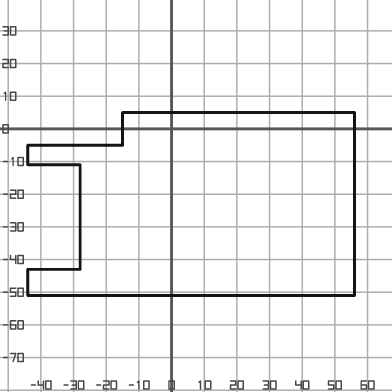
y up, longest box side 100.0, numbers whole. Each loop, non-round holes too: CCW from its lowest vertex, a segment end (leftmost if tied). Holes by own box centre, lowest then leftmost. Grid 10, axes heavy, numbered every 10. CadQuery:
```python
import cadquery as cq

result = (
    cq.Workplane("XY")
    .moveTo(-44.0, -51.0)
    .lineTo(56.0, -51.0)
    .lineTo(56.0, 5.0)
    .lineTo(-15.0, 5.0)
    .lineTo(-15.0, -5.0)
    .lineTo(-44.0, -5.0)
    .lineTo(-44.0, -11.0)
    .lineTo(-28.0, -11.0)
    .lineTo(-28.0, -43.0)
    .lineTo(-44.0, -43.0)
    .close()
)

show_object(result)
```